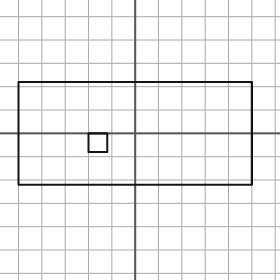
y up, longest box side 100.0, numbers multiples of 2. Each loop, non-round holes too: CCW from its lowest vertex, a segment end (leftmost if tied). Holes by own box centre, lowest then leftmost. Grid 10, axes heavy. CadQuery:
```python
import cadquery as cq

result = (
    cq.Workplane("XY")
    .moveTo(-50.0, -22.0)
    .lineTo(50.0, -22.0)
    .lineTo(50.0, 22.0)
    .lineTo(-50.0, 22.0)
    .close()
    .moveTo(-20.0, -8.0)
    .lineTo(-12.0, -8.0)
    .lineTo(-12.0, 0.0)
    .lineTo(-20.0, 0.0)
    .close()
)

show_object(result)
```